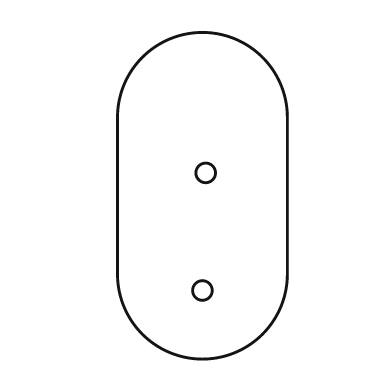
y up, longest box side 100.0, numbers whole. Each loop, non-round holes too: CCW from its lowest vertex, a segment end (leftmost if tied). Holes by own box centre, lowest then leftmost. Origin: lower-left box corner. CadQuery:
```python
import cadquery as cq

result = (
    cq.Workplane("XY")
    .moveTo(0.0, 26.0)
    .threePointArc((26.0, 0.0), (52.0, 26.0))
    .lineTo(52.0, 74.0)
    .threePointArc((26.0, 100.0), (0.0, 74.0))
    .close()
    .moveTo(26.0, 21.0)
    .circle(3.0)
    .moveTo(27.0, 57.0)
    .circle(3.0)
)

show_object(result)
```